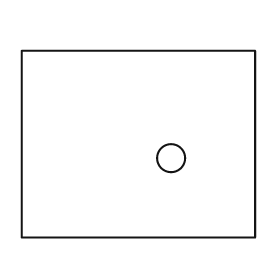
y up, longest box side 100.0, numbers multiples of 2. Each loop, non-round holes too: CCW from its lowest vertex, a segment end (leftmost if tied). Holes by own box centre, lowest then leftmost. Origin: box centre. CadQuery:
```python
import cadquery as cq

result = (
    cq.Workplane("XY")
    .moveTo(-50.0, -40.0)
    .lineTo(50.0, -40.0)
    .lineTo(50.0, 40.0)
    .lineTo(-50.0, 40.0)
    .close()
    .moveTo(14.0, -6.0)
    .circle(6.0)
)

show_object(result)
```